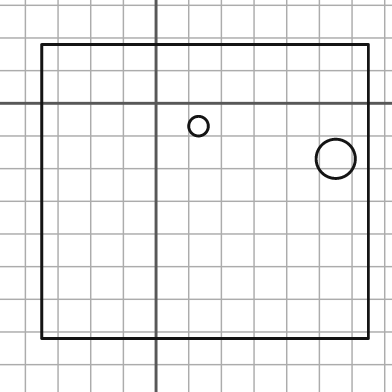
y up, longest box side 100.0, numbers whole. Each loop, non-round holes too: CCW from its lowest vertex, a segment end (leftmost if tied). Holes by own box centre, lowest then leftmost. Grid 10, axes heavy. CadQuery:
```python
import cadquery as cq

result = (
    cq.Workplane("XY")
    .moveTo(-35.0, -72.0)
    .lineTo(65.0, -72.0)
    .lineTo(65.0, 18.0)
    .lineTo(-35.0, 18.0)
    .close()
    .moveTo(55.0, -17.0)
    .circle(6.0)
    .moveTo(13.0, -7.0)
    .circle(3.0)
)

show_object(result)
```